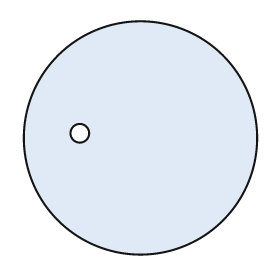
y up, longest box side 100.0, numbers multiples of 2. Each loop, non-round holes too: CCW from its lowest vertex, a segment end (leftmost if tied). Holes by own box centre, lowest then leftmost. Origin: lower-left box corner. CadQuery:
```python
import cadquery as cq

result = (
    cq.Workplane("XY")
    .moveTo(50.0, 50.0)
    .circle(50.0)
    .moveTo(24.0, 52.0)
    .circle(4.0)
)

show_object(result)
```